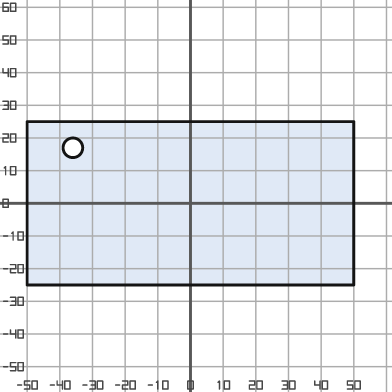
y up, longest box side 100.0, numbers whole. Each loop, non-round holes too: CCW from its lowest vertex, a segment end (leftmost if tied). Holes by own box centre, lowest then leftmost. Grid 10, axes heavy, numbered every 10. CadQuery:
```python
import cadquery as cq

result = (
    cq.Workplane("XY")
    .moveTo(-50.0, -25.0)
    .lineTo(50.0, -25.0)
    .lineTo(50.0, 25.0)
    .lineTo(-50.0, 25.0)
    .close()
    .moveTo(-36.0, 17.0)
    .circle(3.0)
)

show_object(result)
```